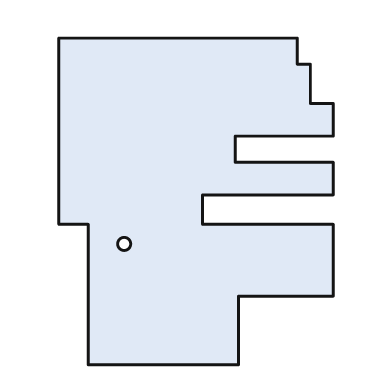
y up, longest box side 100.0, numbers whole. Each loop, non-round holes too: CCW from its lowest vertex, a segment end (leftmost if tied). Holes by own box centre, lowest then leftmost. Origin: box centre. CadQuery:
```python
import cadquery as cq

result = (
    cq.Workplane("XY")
    .moveTo(-33.0, -50.0)
    .lineTo(13.0, -50.0)
    .lineTo(13.0, -29.0)
    .lineTo(42.0, -29.0)
    .lineTo(42.0, -7.0)
    .lineTo(2.0, -7.0)
    .lineTo(2.0, 2.0)
    .lineTo(42.0, 2.0)
    .lineTo(42.0, 12.0)
    .lineTo(12.0, 12.0)
    .lineTo(12.0, 20.0)
    .lineTo(42.0, 20.0)
    .lineTo(42.0, 30.0)
    .lineTo(35.0, 30.0)
    .lineTo(35.0, 42.0)
    .lineTo(31.0, 42.0)
    .lineTo(31.0, 50.0)
    .lineTo(-42.0, 50.0)
    .lineTo(-42.0, -7.0)
    .lineTo(-33.0, -7.0)
    .close()
    .moveTo(-22.0, -13.0)
    .circle(2.0)
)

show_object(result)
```